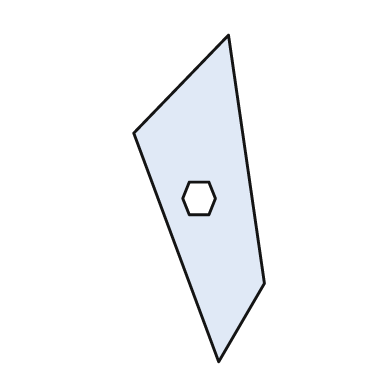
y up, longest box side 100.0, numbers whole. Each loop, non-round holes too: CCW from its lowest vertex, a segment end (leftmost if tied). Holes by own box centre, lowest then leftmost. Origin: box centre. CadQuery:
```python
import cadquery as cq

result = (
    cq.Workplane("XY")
    .moveTo(6.0, -50.0)
    .lineTo(20.0, -26.0)
    .lineTo(9.0, 50.0)
    .lineTo(-20.0, 20.0)
    .close()
    .moveTo(-3.0, -5.0)
    .lineTo(3.0, -5.0)
    .lineTo(5.0, 0.0)
    .lineTo(3.0, 5.0)
    .lineTo(-3.0, 5.0)
    .lineTo(-5.0, 0.0)
    .close()
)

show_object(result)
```